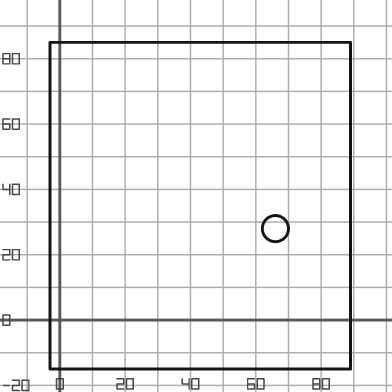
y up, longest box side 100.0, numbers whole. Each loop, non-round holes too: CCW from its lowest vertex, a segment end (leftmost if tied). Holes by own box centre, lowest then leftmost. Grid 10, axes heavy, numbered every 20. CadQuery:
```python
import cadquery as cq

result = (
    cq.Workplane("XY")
    .moveTo(-3.0, -15.0)
    .lineTo(89.0, -15.0)
    .lineTo(89.0, 85.0)
    .lineTo(-3.0, 85.0)
    .close()
    .moveTo(66.0, 28.0)
    .circle(4.0)
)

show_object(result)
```